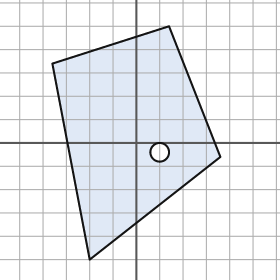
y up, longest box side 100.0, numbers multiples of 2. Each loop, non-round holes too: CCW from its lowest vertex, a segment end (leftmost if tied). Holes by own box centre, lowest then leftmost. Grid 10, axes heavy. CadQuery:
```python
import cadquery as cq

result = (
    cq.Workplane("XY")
    .moveTo(-20.0, -50.0)
    .lineTo(36.0, -6.0)
    .lineTo(14.0, 50.0)
    .lineTo(-36.0, 34.0)
    .close()
    .moveTo(10.0, -4.0)
    .circle(4.0)
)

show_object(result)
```